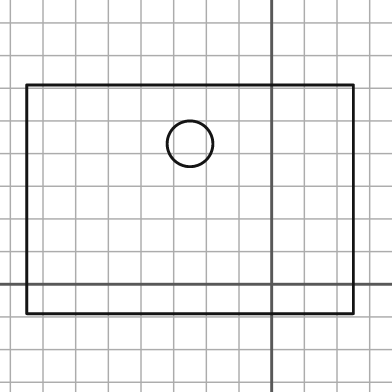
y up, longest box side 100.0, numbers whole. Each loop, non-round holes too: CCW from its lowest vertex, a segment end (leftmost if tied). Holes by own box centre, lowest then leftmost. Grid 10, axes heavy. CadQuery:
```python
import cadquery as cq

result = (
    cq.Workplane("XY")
    .moveTo(-75.0, -9.0)
    .lineTo(25.0, -9.0)
    .lineTo(25.0, 61.0)
    .lineTo(-75.0, 61.0)
    .close()
    .moveTo(-25.0, 43.0)
    .circle(7.0)
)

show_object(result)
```